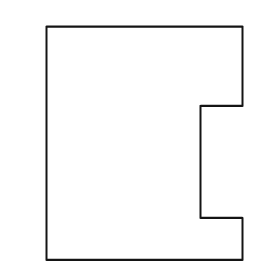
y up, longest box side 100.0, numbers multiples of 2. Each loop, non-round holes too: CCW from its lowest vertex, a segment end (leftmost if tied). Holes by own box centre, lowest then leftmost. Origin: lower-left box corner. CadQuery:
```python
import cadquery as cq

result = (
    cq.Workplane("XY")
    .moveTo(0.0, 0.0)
    .lineTo(84.0, 0.0)
    .lineTo(84.0, 18.0)
    .lineTo(66.0, 18.0)
    .lineTo(66.0, 66.0)
    .lineTo(84.0, 66.0)
    .lineTo(84.0, 100.0)
    .lineTo(0.0, 100.0)
    .close()
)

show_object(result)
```